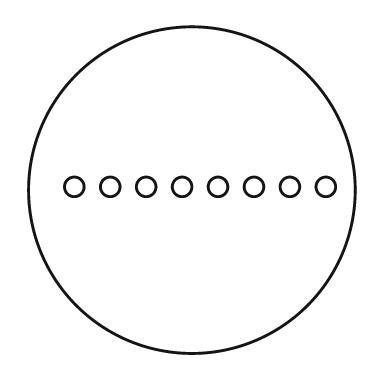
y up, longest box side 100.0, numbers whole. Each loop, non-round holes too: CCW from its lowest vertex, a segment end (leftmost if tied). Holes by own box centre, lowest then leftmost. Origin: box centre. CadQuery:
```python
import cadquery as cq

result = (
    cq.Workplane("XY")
    .moveTo(0.0, 0.0)
    .circle(50.0)
    .moveTo(-36.0, 1.0)
    .circle(3.0)
    .moveTo(-25.0, 1.0)
    .circle(3.0)
    .moveTo(-14.0, 1.0)
    .circle(3.0)
    .moveTo(-3.0, 1.0)
    .circle(3.0)
    .moveTo(8.0, 1.0)
    .circle(3.0)
    .moveTo(19.0, 1.0)
    .circle(3.0)
    .moveTo(30.0, 1.0)
    .circle(3.0)
    .moveTo(41.0, 1.0)
    .circle(3.0)
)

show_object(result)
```